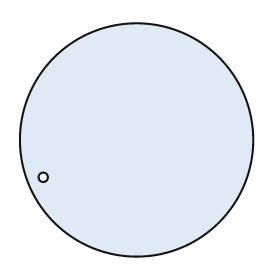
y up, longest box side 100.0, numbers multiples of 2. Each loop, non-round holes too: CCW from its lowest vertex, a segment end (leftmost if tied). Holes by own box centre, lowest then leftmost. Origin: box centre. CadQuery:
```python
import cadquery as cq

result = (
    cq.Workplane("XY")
    .moveTo(0.0, 0.0)
    .circle(50.0)
    .moveTo(-40.0, -16.0)
    .circle(2.0)
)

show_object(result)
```